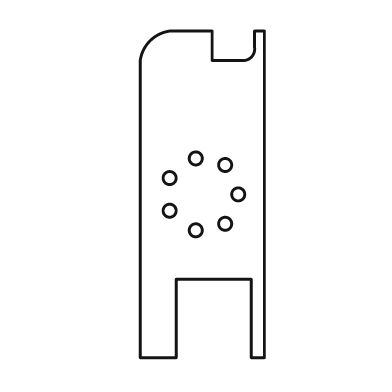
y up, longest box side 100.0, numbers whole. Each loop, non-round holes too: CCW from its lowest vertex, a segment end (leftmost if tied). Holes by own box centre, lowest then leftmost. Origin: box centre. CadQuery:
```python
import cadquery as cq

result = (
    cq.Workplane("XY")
    .moveTo(-19.0, -50.0)
    .lineTo(-8.0, -50.0)
    .lineTo(-8.0, -26.0)
    .lineTo(15.0, -26.0)
    .lineTo(15.0, -50.0)
    .lineTo(19.0, -50.0)
    .lineTo(19.0, 50.0)
    .lineTo(16.0, 50.0)
    .lineTo(16.0, 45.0)
    .threePointArc((15.0, 42.0), (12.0, 41.0))
    .lineTo(3.0, 41.0)
    .lineTo(3.0, 50.0)
    .lineTo(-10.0, 50.0)
    .threePointArc((-16.0, 47.0), (-19.0, 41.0))
    .close()
    .moveTo(-2.0, -11.0)
    .circle(2.0)
    .moveTo(7.0, -9.0)
    .circle(2.0)
    .moveTo(-10.0, -5.0)
    .circle(2.0)
    .moveTo(11.0, 0.0)
    .circle(2.0)
    .moveTo(-10.0, 5.0)
    .circle(2.0)
    .moveTo(7.0, 9.0)
    .circle(2.0)
    .moveTo(-2.0, 11.0)
    .circle(2.0)
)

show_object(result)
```